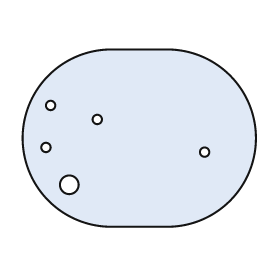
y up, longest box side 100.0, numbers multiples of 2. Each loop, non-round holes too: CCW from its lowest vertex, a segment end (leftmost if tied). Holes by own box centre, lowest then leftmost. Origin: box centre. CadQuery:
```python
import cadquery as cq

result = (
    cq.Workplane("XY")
    .moveTo(-12.0, -38.0)
    .lineTo(12.0, -38.0)
    .threePointArc((50.0, 0.0), (12.0, 38.0))
    .lineTo(-12.0, 38.0)
    .threePointArc((-50.0, 0.0), (-12.0, -38.0))
    .close()
    .moveTo(-30.0, -20.0)
    .circle(4.0)
    .moveTo(28.0, -6.0)
    .circle(2.0)
    .moveTo(-40.0, -4.0)
    .circle(2.0)
    .moveTo(-18.0, 8.0)
    .circle(2.0)
    .moveTo(-38.0, 14.0)
    .circle(2.0)
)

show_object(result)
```